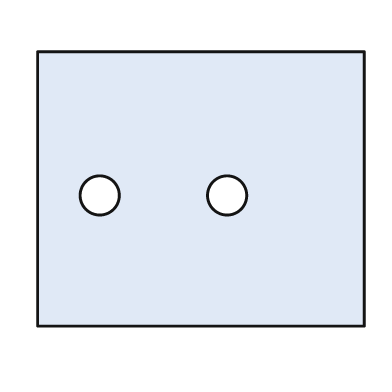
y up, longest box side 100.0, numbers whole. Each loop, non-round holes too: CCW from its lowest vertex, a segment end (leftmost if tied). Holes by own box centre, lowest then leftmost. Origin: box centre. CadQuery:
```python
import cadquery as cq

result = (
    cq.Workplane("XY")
    .moveTo(-50.0, -42.0)
    .lineTo(50.0, -42.0)
    .lineTo(50.0, 42.0)
    .lineTo(-50.0, 42.0)
    .close()
    .moveTo(-31.0, -2.0)
    .circle(6.0)
    .moveTo(8.0, -2.0)
    .circle(6.0)
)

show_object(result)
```